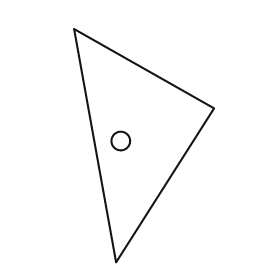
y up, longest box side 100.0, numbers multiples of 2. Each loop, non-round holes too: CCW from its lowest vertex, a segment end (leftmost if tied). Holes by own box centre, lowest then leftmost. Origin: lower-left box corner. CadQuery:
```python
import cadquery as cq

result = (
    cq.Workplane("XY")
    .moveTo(18.0, 0.0)
    .lineTo(60.0, 66.0)
    .lineTo(0.0, 100.0)
    .close()
    .moveTo(20.0, 52.0)
    .circle(4.0)
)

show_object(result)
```